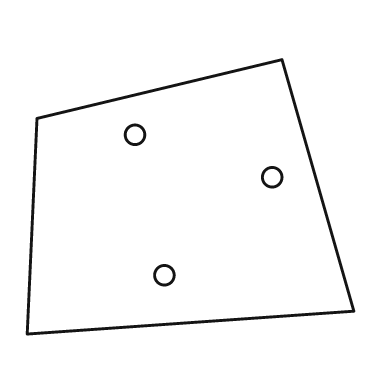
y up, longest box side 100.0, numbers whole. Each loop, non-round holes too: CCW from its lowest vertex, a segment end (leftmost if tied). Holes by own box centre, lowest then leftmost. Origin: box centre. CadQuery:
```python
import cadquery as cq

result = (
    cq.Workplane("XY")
    .moveTo(-50.0, -42.0)
    .lineTo(50.0, -35.0)
    .lineTo(28.0, 42.0)
    .lineTo(-47.0, 24.0)
    .close()
    .moveTo(-8.0, -24.0)
    .circle(3.0)
    .moveTo(25.0, 6.0)
    .circle(3.0)
    .moveTo(-17.0, 19.0)
    .circle(3.0)
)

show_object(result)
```